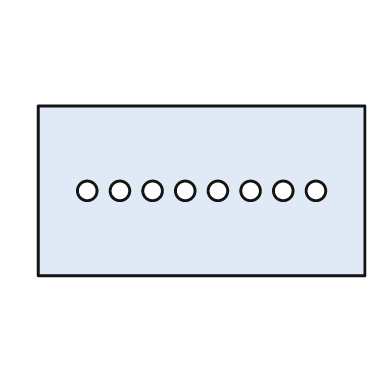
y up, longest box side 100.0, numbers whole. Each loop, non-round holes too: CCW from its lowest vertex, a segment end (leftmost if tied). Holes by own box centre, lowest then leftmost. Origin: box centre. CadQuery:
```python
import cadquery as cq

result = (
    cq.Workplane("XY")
    .moveTo(-50.0, -26.0)
    .lineTo(50.0, -26.0)
    .lineTo(50.0, 26.0)
    .lineTo(-50.0, 26.0)
    .close()
    .moveTo(-35.0, 0.0)
    .circle(3.0)
    .moveTo(-25.0, 0.0)
    .circle(3.0)
    .moveTo(-15.0, 0.0)
    .circle(3.0)
    .moveTo(-5.0, 0.0)
    .circle(3.0)
    .moveTo(5.0, 0.0)
    .circle(3.0)
    .moveTo(15.0, 0.0)
    .circle(3.0)
    .moveTo(25.0, 0.0)
    .circle(3.0)
    .moveTo(35.0, 0.0)
    .circle(3.0)
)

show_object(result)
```